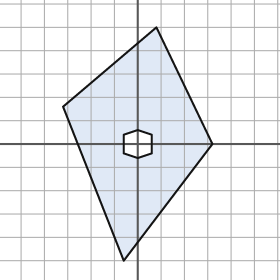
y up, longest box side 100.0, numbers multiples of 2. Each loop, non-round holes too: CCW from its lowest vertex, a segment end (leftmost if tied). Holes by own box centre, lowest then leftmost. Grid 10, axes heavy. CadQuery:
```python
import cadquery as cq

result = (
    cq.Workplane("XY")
    .moveTo(-6.0, -50.0)
    .lineTo(32.0, 0.0)
    .lineTo(8.0, 50.0)
    .lineTo(-32.0, 16.0)
    .close()
    .moveTo(0.0, -6.0)
    .lineTo(6.0, -4.0)
    .lineTo(6.0, 4.0)
    .lineTo(0.0, 6.0)
    .lineTo(-6.0, 4.0)
    .lineTo(-6.0, -4.0)
    .close()
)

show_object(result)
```